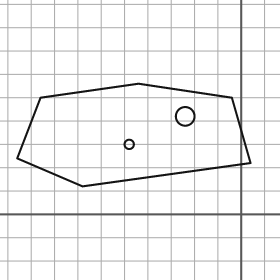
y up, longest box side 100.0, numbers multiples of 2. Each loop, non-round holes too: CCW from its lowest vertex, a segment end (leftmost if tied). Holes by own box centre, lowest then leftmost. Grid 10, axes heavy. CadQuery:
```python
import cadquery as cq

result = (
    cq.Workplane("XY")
    .moveTo(-68.0, 12.0)
    .lineTo(4.0, 22.0)
    .lineTo(-4.0, 50.0)
    .lineTo(-44.0, 56.0)
    .lineTo(-86.0, 50.0)
    .lineTo(-96.0, 24.0)
    .close()
    .moveTo(-48.0, 30.0)
    .circle(2.0)
    .moveTo(-24.0, 42.0)
    .circle(4.0)
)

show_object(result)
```